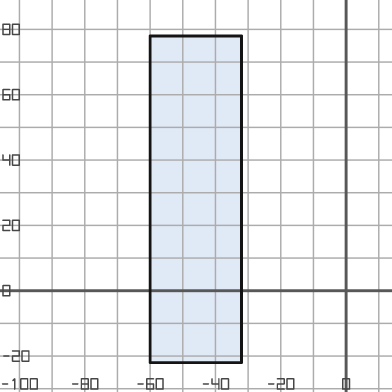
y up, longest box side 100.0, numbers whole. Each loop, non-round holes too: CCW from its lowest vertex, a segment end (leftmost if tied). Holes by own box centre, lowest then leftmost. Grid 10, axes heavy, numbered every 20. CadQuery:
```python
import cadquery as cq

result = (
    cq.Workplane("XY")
    .moveTo(-60.0, -22.0)
    .lineTo(-32.0, -22.0)
    .lineTo(-32.0, 78.0)
    .lineTo(-60.0, 78.0)
    .close()
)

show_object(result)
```